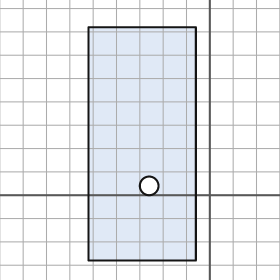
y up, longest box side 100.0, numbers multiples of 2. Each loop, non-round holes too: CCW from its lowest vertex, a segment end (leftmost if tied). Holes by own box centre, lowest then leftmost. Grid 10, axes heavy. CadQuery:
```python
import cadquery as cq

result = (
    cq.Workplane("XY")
    .moveTo(-52.0, -28.0)
    .lineTo(-6.0, -28.0)
    .lineTo(-6.0, 72.0)
    .lineTo(-52.0, 72.0)
    .close()
    .moveTo(-26.0, 4.0)
    .circle(4.0)
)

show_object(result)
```